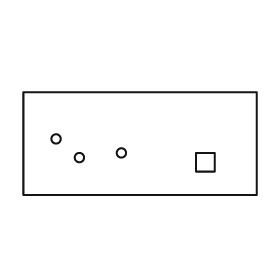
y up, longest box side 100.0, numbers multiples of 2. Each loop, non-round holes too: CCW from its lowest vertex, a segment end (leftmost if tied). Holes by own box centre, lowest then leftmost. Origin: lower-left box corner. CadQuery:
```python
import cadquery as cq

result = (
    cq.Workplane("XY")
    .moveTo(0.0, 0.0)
    .lineTo(100.0, 0.0)
    .lineTo(100.0, 44.0)
    .lineTo(0.0, 44.0)
    .close()
    .moveTo(74.0, 10.0)
    .lineTo(82.0, 10.0)
    .lineTo(82.0, 18.0)
    .lineTo(74.0, 18.0)
    .close()
    .moveTo(24.0, 16.0)
    .circle(2.0)
    .moveTo(42.0, 18.0)
    .circle(2.0)
    .moveTo(14.0, 24.0)
    .circle(2.0)
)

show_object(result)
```